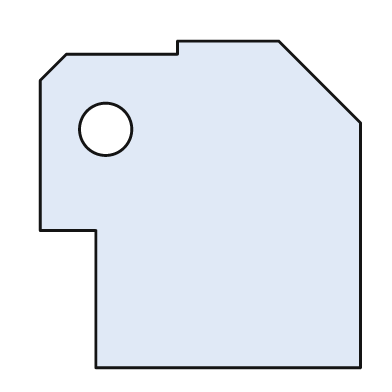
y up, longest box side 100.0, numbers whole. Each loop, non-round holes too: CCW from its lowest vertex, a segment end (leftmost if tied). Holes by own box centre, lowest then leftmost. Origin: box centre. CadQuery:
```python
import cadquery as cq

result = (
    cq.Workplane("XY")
    .moveTo(-32.0, -50.0)
    .lineTo(49.0, -50.0)
    .lineTo(49.0, 25.0)
    .lineTo(24.0, 50.0)
    .lineTo(-7.0, 50.0)
    .lineTo(-7.0, 46.0)
    .lineTo(-41.0, 46.0)
    .lineTo(-49.0, 38.0)
    .lineTo(-49.0, -8.0)
    .lineTo(-32.0, -8.0)
    .close()
    .moveTo(-29.0, 23.0)
    .circle(8.0)
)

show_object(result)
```